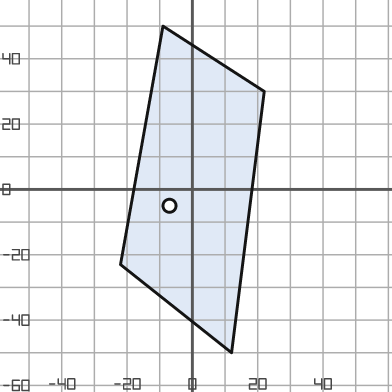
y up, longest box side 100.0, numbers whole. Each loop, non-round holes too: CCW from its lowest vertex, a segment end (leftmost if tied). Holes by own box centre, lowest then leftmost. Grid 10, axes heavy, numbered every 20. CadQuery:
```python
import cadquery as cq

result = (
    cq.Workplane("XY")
    .moveTo(12.0, -50.0)
    .lineTo(22.0, 30.0)
    .lineTo(-9.0, 50.0)
    .lineTo(-22.0, -23.0)
    .close()
    .moveTo(-7.0, -5.0)
    .circle(2.0)
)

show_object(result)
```